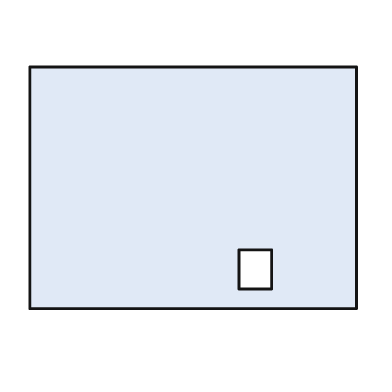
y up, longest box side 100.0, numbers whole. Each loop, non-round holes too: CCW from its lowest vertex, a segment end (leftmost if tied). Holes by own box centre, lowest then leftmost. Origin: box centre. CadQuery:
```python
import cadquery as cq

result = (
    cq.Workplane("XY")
    .moveTo(-50.0, -37.0)
    .lineTo(50.0, -37.0)
    .lineTo(50.0, 37.0)
    .lineTo(-50.0, 37.0)
    .close()
    .moveTo(14.0, -31.0)
    .lineTo(24.0, -31.0)
    .lineTo(24.0, -19.0)
    .lineTo(14.0, -19.0)
    .close()
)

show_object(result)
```